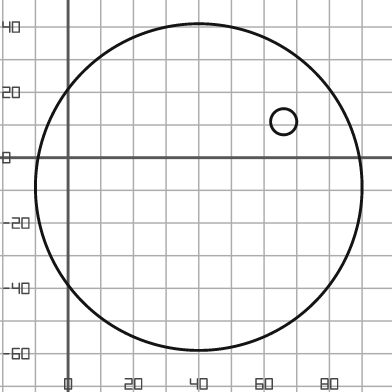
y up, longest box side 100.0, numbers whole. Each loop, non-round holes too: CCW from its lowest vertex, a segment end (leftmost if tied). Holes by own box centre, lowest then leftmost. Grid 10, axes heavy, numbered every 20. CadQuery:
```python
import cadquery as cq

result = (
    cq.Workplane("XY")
    .moveTo(40.0, -9.0)
    .circle(50.0)
    .moveTo(66.0, 11.0)
    .circle(4.0)
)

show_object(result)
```